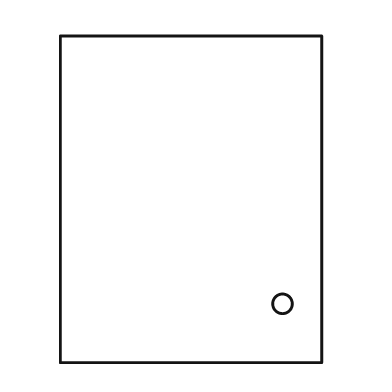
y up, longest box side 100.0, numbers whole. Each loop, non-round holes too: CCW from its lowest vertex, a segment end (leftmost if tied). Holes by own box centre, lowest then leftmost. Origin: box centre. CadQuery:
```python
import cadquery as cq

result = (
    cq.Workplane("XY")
    .moveTo(-40.0, -50.0)
    .lineTo(40.0, -50.0)
    .lineTo(40.0, 50.0)
    .lineTo(-40.0, 50.0)
    .close()
    .moveTo(28.0, -32.0)
    .circle(3.0)
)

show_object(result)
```